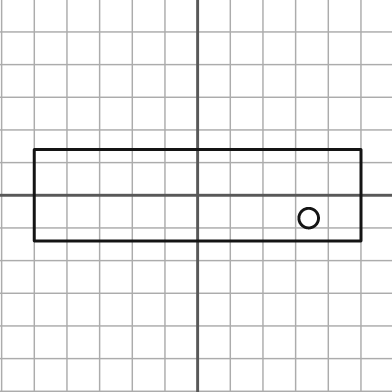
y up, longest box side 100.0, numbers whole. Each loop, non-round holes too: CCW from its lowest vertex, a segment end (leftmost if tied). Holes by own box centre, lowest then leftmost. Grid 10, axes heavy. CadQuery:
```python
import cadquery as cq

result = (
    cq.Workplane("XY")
    .moveTo(-50.0, -14.0)
    .lineTo(50.0, -14.0)
    .lineTo(50.0, 14.0)
    .lineTo(-50.0, 14.0)
    .close()
    .moveTo(34.0, -7.0)
    .circle(3.0)
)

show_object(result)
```